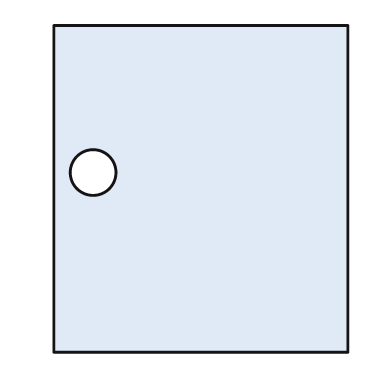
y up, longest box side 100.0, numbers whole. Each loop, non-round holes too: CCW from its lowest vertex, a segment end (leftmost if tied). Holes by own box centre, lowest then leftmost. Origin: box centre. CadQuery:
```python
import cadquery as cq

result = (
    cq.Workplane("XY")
    .moveTo(-45.0, -50.0)
    .lineTo(45.0, -50.0)
    .lineTo(45.0, 50.0)
    .lineTo(-45.0, 50.0)
    .close()
    .moveTo(-33.0, 5.0)
    .circle(7.0)
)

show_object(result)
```